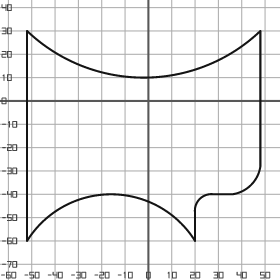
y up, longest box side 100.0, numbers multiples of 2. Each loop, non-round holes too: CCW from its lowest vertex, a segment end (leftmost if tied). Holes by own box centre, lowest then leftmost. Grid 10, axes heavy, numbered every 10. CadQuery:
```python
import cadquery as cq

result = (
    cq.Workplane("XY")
    .moveTo(-52.0, -60.0)
    .threePointArc((-16.0, -40.0), (20.0, -60.0))
    .lineTo(20.0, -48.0)
    .threePointArc((22.0, -42.0), (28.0, -40.0))
    .lineTo(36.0, -40.0)
    .threePointArc((44.0, -36.0), (48.0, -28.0))
    .lineTo(48.0, 30.0)
    .threePointArc((-2.0, 10.0), (-52.0, 30.0))
    .close()
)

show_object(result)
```